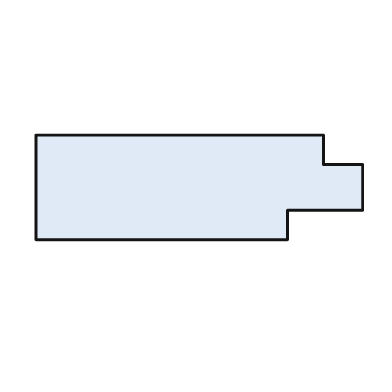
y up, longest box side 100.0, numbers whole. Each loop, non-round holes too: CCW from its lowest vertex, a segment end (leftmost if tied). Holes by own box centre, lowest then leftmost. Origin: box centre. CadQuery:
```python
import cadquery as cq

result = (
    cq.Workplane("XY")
    .moveTo(-50.0, -16.0)
    .lineTo(27.0, -16.0)
    .lineTo(27.0, -7.0)
    .lineTo(50.0, -7.0)
    .lineTo(50.0, 7.0)
    .lineTo(38.0, 7.0)
    .lineTo(38.0, 16.0)
    .lineTo(-50.0, 16.0)
    .close()
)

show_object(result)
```